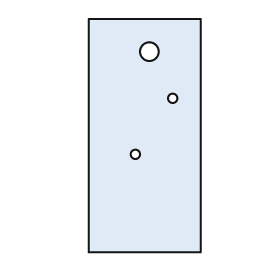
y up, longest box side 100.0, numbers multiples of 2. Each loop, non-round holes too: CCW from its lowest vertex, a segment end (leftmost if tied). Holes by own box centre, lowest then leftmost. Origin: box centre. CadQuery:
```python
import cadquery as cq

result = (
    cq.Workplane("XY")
    .moveTo(-24.0, -50.0)
    .lineTo(24.0, -50.0)
    .lineTo(24.0, 50.0)
    .lineTo(-24.0, 50.0)
    .close()
    .moveTo(-4.0, -8.0)
    .circle(2.0)
    .moveTo(12.0, 16.0)
    .circle(2.0)
    .moveTo(2.0, 36.0)
    .circle(4.0)
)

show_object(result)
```